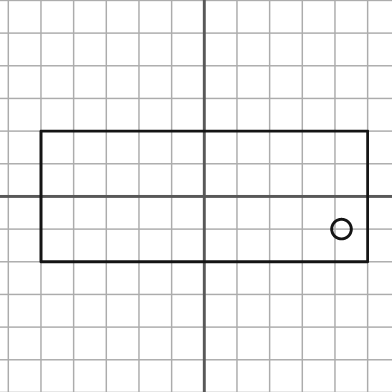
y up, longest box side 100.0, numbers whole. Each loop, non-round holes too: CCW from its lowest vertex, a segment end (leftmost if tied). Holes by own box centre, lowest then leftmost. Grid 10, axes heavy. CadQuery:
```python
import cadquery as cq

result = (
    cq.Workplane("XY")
    .moveTo(-50.0, -20.0)
    .lineTo(50.0, -20.0)
    .lineTo(50.0, 20.0)
    .lineTo(-50.0, 20.0)
    .close()
    .moveTo(42.0, -10.0)
    .circle(3.0)
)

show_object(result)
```